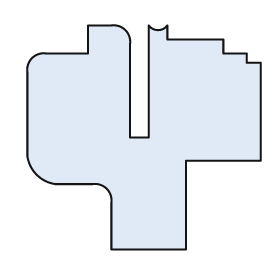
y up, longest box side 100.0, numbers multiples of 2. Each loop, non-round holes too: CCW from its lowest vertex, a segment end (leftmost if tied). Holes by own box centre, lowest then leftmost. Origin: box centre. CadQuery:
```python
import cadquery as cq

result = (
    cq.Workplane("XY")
    .moveTo(-14.0, -48.0)
    .lineTo(18.0, -48.0)
    .lineTo(18.0, -10.0)
    .lineTo(50.0, -10.0)
    .lineTo(50.0, 32.0)
    .lineTo(44.0, 32.0)
    .lineTo(44.0, 36.0)
    .lineTo(34.0, 36.0)
    .lineTo(34.0, 42.0)
    .lineTo(10.0, 42.0)
    .lineTo(10.0, 48.0)
    .threePointArc((6.0, 46.0), (2.0, 48.0))
    .lineTo(2.0, 0.0)
    .lineTo(-6.0, 0.0)
    .lineTo(-6.0, 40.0)
    .threePointArc((-8.0, 46.0), (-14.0, 48.0))
    .lineTo(-24.0, 48.0)
    .lineTo(-24.0, 36.0)
    .lineTo(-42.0, 36.0)
    .threePointArc((-48.0, 34.0), (-50.0, 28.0))
    .lineTo(-50.0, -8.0)
    .threePointArc((-46.0, -16.0), (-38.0, -20.0))
    .lineTo(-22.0, -20.0)
    .threePointArc((-16.0, -22.0), (-14.0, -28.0))
    .close()
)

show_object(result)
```